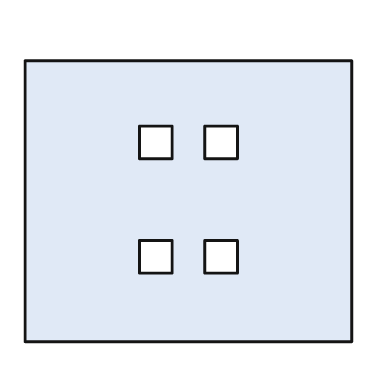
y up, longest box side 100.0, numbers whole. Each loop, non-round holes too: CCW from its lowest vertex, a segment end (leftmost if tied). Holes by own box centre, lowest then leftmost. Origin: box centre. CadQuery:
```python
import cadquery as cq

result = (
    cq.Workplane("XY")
    .moveTo(-50.0, -43.0)
    .lineTo(50.0, -43.0)
    .lineTo(50.0, 43.0)
    .lineTo(-50.0, 43.0)
    .close()
    .moveTo(-15.0, -22.0)
    .lineTo(-5.0, -22.0)
    .lineTo(-5.0, -12.0)
    .lineTo(-15.0, -12.0)
    .close()
    .moveTo(5.0, -22.0)
    .lineTo(15.0, -22.0)
    .lineTo(15.0, -12.0)
    .lineTo(5.0, -12.0)
    .close()
    .moveTo(-15.0, 13.0)
    .lineTo(-5.0, 13.0)
    .lineTo(-5.0, 23.0)
    .lineTo(-15.0, 23.0)
    .close()
    .moveTo(5.0, 13.0)
    .lineTo(15.0, 13.0)
    .lineTo(15.0, 23.0)
    .lineTo(5.0, 23.0)
    .close()
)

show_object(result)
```